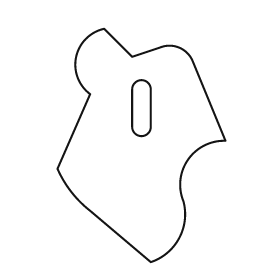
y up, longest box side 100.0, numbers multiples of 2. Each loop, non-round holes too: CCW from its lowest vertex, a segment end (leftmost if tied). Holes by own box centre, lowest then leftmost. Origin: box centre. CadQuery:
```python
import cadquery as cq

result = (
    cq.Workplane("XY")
    .moveTo(4.0, -50.0)
    .threePointArc((16.0, -40.0), (18.0, -24.0))
    .threePointArc((20.0, -6.0), (36.0, 2.0))
    .lineTo(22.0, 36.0)
    .threePointArc((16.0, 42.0), (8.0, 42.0))
    .lineTo(-4.0, 38.0)
    .lineTo(-16.0, 50.0)
    .threePointArc((-28.0, 38.0), (-22.0, 22.0))
    .lineTo(-36.0, -10.0)
    .threePointArc((-30.0, -20.0), (-22.0, -28.0))
    .close()
    .moveTo(-4.0, 8.0)
    .threePointArc((0.0, 4.0), (4.0, 8.0))
    .lineTo(4.0, 24.0)
    .threePointArc((0.0, 28.0), (-4.0, 24.0))
    .close()
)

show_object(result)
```